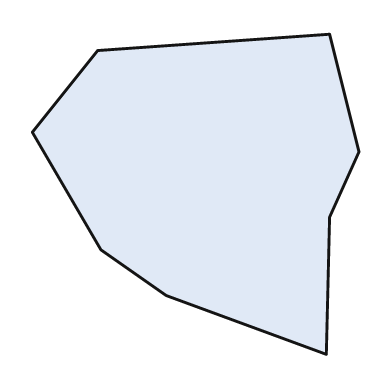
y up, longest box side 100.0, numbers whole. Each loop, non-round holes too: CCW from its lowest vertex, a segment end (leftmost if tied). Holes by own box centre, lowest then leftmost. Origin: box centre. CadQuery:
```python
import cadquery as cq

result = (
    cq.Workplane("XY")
    .moveTo(40.0, -49.0)
    .lineTo(41.0, -7.0)
    .lineTo(50.0, 13.0)
    .lineTo(41.0, 49.0)
    .lineTo(-30.0, 44.0)
    .lineTo(-50.0, 19.0)
    .lineTo(-29.0, -17.0)
    .lineTo(-9.0, -31.0)
    .close()
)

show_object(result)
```